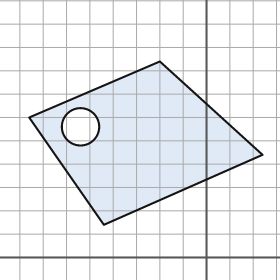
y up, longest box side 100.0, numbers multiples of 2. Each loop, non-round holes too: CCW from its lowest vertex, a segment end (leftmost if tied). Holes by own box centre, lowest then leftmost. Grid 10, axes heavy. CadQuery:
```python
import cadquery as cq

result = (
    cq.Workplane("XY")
    .moveTo(-44.0, 14.0)
    .lineTo(24.0, 44.0)
    .lineTo(-20.0, 84.0)
    .lineTo(-76.0, 60.0)
    .close()
    .moveTo(-54.0, 56.0)
    .circle(8.0)
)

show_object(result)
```